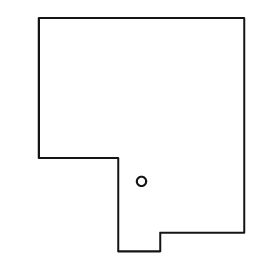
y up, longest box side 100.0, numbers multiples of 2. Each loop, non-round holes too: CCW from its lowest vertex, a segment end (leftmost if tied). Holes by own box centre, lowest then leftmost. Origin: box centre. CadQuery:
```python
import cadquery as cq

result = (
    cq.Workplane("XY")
    .moveTo(-10.0, -50.0)
    .lineTo(8.0, -50.0)
    .lineTo(8.0, -42.0)
    .lineTo(44.0, -42.0)
    .lineTo(44.0, 50.0)
    .lineTo(-44.0, 50.0)
    .lineTo(-44.0, -10.0)
    .lineTo(-10.0, -10.0)
    .close()
    .moveTo(0.0, -20.0)
    .circle(2.0)
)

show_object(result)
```